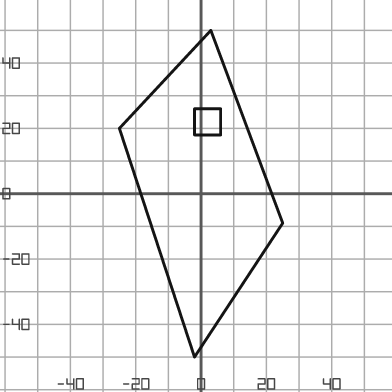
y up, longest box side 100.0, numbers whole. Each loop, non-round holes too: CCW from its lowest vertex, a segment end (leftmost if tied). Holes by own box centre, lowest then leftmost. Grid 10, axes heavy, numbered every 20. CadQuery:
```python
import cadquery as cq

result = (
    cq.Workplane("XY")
    .moveTo(-2.0, -50.0)
    .lineTo(25.0, -9.0)
    .lineTo(3.0, 50.0)
    .lineTo(-25.0, 20.0)
    .close()
    .moveTo(-2.0, 18.0)
    .lineTo(6.0, 18.0)
    .lineTo(6.0, 26.0)
    .lineTo(-2.0, 26.0)
    .close()
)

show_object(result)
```